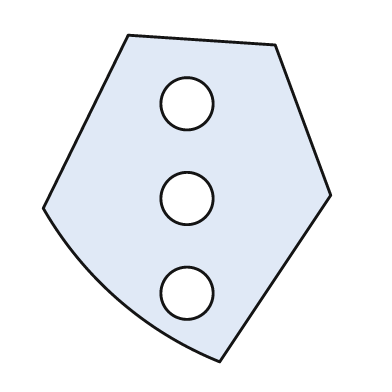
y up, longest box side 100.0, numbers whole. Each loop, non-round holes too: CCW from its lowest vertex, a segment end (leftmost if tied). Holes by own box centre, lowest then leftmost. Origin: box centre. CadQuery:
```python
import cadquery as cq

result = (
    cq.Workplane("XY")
    .moveTo(10.0, -50.0)
    .lineTo(44.0, 1.0)
    .lineTo(27.0, 47.0)
    .lineTo(-18.0, 50.0)
    .lineTo(-44.0, -3.0)
    .threePointArc((-21.0, -31.0), (10.0, -50.0))
    .close()
    .moveTo(0.0, -29.0)
    .circle(8.0)
    .moveTo(0.0, 0.0)
    .circle(8.0)
    .moveTo(0.0, 29.0)
    .circle(8.0)
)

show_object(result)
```